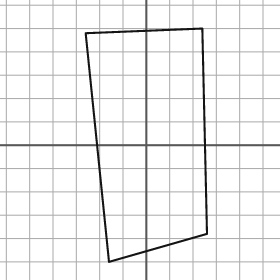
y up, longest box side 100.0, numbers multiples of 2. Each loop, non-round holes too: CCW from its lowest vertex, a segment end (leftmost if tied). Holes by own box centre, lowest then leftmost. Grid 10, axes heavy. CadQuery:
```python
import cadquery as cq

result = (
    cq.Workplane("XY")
    .moveTo(-16.0, -50.0)
    .lineTo(26.0, -38.0)
    .lineTo(24.0, 50.0)
    .lineTo(-26.0, 48.0)
    .close()
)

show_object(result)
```